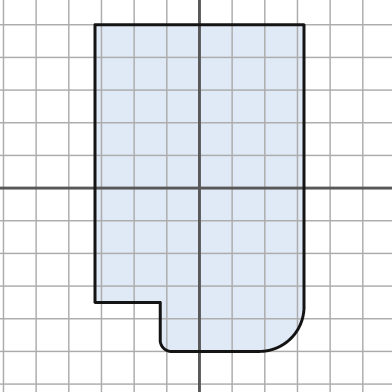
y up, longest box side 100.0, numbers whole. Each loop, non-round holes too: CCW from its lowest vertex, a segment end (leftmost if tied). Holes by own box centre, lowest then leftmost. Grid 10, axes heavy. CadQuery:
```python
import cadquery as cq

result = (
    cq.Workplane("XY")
    .moveTo(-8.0, -50.0)
    .lineTo(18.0, -50.0)
    .threePointArc((28.0, -46.0), (32.0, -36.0))
    .lineTo(32.0, 50.0)
    .lineTo(-32.0, 50.0)
    .lineTo(-32.0, -35.0)
    .lineTo(-12.0, -35.0)
    .lineTo(-12.0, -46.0)
    .threePointArc((-11.0, -49.0), (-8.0, -50.0))
    .close()
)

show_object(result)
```